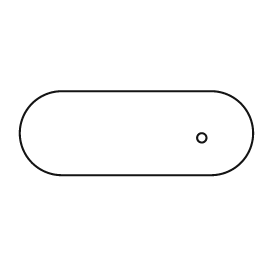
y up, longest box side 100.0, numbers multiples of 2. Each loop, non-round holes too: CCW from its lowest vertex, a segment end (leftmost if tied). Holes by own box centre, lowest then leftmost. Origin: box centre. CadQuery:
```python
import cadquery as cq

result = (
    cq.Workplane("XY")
    .moveTo(-32.0, -18.0)
    .lineTo(32.0, -18.0)
    .threePointArc((50.0, 0.0), (32.0, 18.0))
    .lineTo(-32.0, 18.0)
    .threePointArc((-50.0, 0.0), (-32.0, -18.0))
    .close()
    .moveTo(28.0, -2.0)
    .circle(2.0)
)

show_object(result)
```